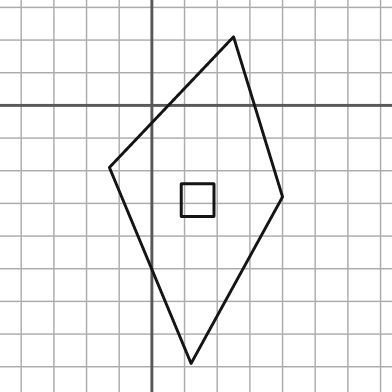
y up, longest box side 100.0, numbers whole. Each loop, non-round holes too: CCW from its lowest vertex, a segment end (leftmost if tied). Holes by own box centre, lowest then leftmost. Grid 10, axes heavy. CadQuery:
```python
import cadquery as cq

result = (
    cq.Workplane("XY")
    .moveTo(12.0, -79.0)
    .lineTo(40.0, -28.0)
    .lineTo(25.0, 21.0)
    .lineTo(-13.0, -19.0)
    .close()
    .moveTo(9.0, -34.0)
    .lineTo(19.0, -34.0)
    .lineTo(19.0, -24.0)
    .lineTo(9.0, -24.0)
    .close()
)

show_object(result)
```